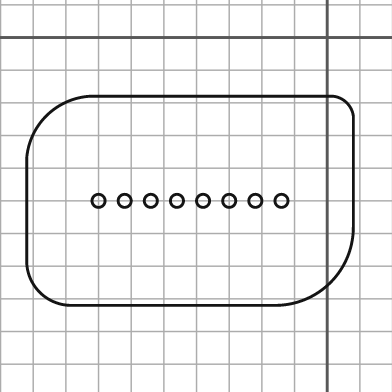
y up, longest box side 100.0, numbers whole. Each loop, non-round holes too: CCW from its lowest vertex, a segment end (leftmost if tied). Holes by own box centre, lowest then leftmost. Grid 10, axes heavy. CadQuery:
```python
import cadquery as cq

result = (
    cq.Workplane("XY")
    .moveTo(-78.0, -82.0)
    .lineTo(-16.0, -82.0)
    .threePointArc((1.0, -75.0), (8.0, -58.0))
    .lineTo(8.0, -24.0)
    .threePointArc((6.0, -20.0), (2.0, -18.0))
    .lineTo(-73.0, -18.0)
    .threePointArc((-86.0, -24.0), (-92.0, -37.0))
    .lineTo(-92.0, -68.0)
    .threePointArc((-88.0, -78.0), (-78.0, -82.0))
    .close()
    .moveTo(-70.0, -50.0)
    .circle(2.0)
    .moveTo(-62.0, -50.0)
    .circle(2.0)
    .moveTo(-54.0, -50.0)
    .circle(2.0)
    .moveTo(-46.0, -50.0)
    .circle(2.0)
    .moveTo(-38.0, -50.0)
    .circle(2.0)
    .moveTo(-30.0, -50.0)
    .circle(2.0)
    .moveTo(-22.0, -50.0)
    .circle(2.0)
    .moveTo(-14.0, -50.0)
    .circle(2.0)
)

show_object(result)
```